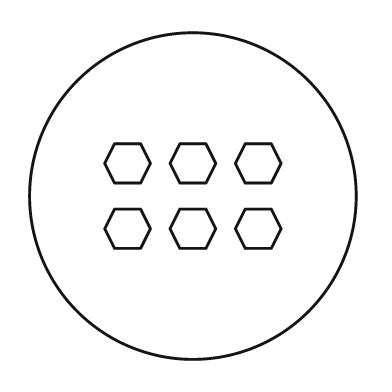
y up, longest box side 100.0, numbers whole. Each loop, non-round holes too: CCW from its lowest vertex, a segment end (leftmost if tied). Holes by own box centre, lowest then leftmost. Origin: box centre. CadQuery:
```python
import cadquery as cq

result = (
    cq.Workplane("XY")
    .moveTo(0.0, 0.0)
    .circle(50.0)
    .moveTo(-24.0, -16.0)
    .lineTo(-16.0, -16.0)
    .lineTo(-13.0, -10.0)
    .lineTo(-16.0, -4.0)
    .lineTo(-24.0, -4.0)
    .lineTo(-27.0, -10.0)
    .close()
    .moveTo(-4.0, -16.0)
    .lineTo(4.0, -16.0)
    .lineTo(7.0, -10.0)
    .lineTo(4.0, -4.0)
    .lineTo(-4.0, -4.0)
    .lineTo(-7.0, -10.0)
    .close()
    .moveTo(16.0, -16.0)
    .lineTo(24.0, -16.0)
    .lineTo(27.0, -10.0)
    .lineTo(24.0, -4.0)
    .lineTo(16.0, -4.0)
    .lineTo(13.0, -10.0)
    .close()
    .moveTo(-24.0, 4.0)
    .lineTo(-16.0, 4.0)
    .lineTo(-13.0, 10.0)
    .lineTo(-16.0, 16.0)
    .lineTo(-24.0, 16.0)
    .lineTo(-27.0, 10.0)
    .close()
    .moveTo(-4.0, 4.0)
    .lineTo(4.0, 4.0)
    .lineTo(7.0, 10.0)
    .lineTo(4.0, 16.0)
    .lineTo(-4.0, 16.0)
    .lineTo(-7.0, 10.0)
    .close()
    .moveTo(16.0, 4.0)
    .lineTo(24.0, 4.0)
    .lineTo(27.0, 10.0)
    .lineTo(24.0, 16.0)
    .lineTo(16.0, 16.0)
    .lineTo(13.0, 10.0)
    .close()
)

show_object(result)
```